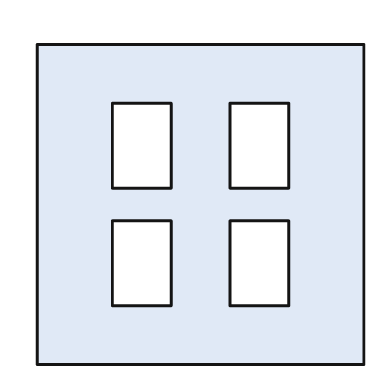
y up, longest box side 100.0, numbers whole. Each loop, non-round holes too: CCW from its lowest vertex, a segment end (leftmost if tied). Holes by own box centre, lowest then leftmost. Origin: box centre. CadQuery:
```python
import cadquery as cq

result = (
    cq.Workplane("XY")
    .moveTo(-50.0, -49.0)
    .lineTo(50.0, -49.0)
    .lineTo(50.0, 49.0)
    .lineTo(-50.0, 49.0)
    .close()
    .moveTo(-27.0, -31.0)
    .lineTo(-9.0, -31.0)
    .lineTo(-9.0, -5.0)
    .lineTo(-27.0, -5.0)
    .close()
    .moveTo(9.0, -31.0)
    .lineTo(27.0, -31.0)
    .lineTo(27.0, -5.0)
    .lineTo(9.0, -5.0)
    .close()
    .moveTo(-27.0, 5.0)
    .lineTo(-9.0, 5.0)
    .lineTo(-9.0, 31.0)
    .lineTo(-27.0, 31.0)
    .close()
    .moveTo(9.0, 5.0)
    .lineTo(27.0, 5.0)
    .lineTo(27.0, 31.0)
    .lineTo(9.0, 31.0)
    .close()
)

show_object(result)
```